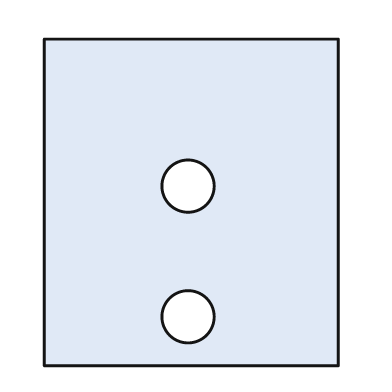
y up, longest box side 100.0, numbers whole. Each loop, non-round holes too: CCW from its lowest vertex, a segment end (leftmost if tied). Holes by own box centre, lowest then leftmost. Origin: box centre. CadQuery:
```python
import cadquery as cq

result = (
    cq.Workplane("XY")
    .moveTo(-45.0, -50.0)
    .lineTo(45.0, -50.0)
    .lineTo(45.0, 50.0)
    .lineTo(-45.0, 50.0)
    .close()
    .moveTo(-1.0, -35.0)
    .circle(8.0)
    .moveTo(-1.0, 5.0)
    .circle(8.0)
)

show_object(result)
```